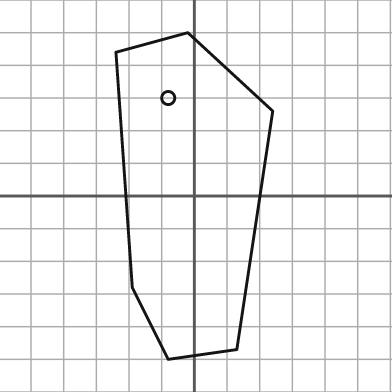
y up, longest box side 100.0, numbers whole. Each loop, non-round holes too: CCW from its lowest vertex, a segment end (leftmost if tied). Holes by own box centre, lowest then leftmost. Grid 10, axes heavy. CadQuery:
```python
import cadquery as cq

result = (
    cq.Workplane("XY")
    .moveTo(-8.0, -50.0)
    .lineTo(13.0, -47.0)
    .lineTo(24.0, 26.0)
    .lineTo(-2.0, 50.0)
    .lineTo(-24.0, 44.0)
    .lineTo(-19.0, -28.0)
    .close()
    .moveTo(-8.0, 30.0)
    .circle(2.0)
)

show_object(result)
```